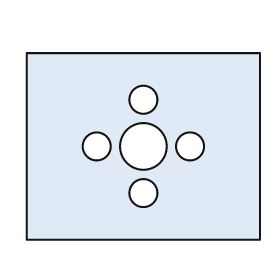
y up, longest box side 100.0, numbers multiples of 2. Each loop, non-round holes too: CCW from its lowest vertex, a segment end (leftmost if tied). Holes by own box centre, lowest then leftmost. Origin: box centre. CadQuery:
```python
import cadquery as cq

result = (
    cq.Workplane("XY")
    .moveTo(-50.0, -40.0)
    .lineTo(50.0, -40.0)
    .lineTo(50.0, 40.0)
    .lineTo(-50.0, 40.0)
    .close()
    .moveTo(0.0, -20.0)
    .circle(6.0)
    .moveTo(-20.0, 0.0)
    .circle(6.0)
    .moveTo(0.0, 0.0)
    .circle(10.0)
    .moveTo(20.0, 0.0)
    .circle(6.0)
    .moveTo(0.0, 20.0)
    .circle(6.0)
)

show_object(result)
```